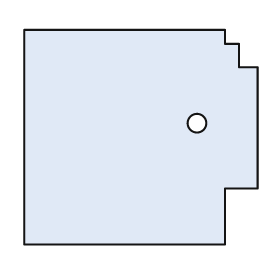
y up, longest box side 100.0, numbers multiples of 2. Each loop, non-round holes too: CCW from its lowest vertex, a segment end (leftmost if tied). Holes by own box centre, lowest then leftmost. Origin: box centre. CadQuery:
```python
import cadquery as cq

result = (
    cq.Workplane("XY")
    .moveTo(-50.0, -46.0)
    .lineTo(36.0, -46.0)
    .lineTo(36.0, -22.0)
    .lineTo(50.0, -22.0)
    .lineTo(50.0, 30.0)
    .lineTo(42.0, 30.0)
    .lineTo(42.0, 40.0)
    .lineTo(36.0, 40.0)
    .lineTo(36.0, 46.0)
    .lineTo(-50.0, 46.0)
    .close()
    .moveTo(24.0, 6.0)
    .circle(4.0)
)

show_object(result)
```